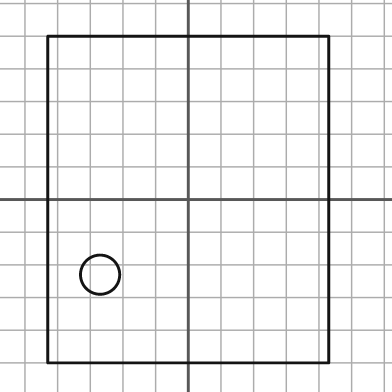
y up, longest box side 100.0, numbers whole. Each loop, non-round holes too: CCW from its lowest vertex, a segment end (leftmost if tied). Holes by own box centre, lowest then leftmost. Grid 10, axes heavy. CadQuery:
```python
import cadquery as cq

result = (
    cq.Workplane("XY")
    .moveTo(-43.0, -50.0)
    .lineTo(43.0, -50.0)
    .lineTo(43.0, 50.0)
    .lineTo(-43.0, 50.0)
    .close()
    .moveTo(-27.0, -23.0)
    .circle(6.0)
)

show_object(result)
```